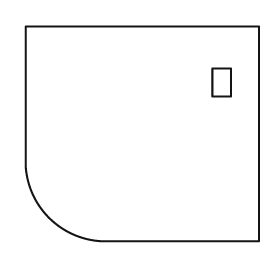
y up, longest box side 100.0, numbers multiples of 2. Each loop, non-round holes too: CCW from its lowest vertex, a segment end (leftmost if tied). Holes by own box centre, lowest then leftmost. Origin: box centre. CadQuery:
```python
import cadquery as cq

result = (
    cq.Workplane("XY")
    .moveTo(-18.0, -46.0)
    .lineTo(50.0, -46.0)
    .lineTo(50.0, 46.0)
    .lineTo(-50.0, 46.0)
    .lineTo(-50.0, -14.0)
    .threePointArc((-40.0, -36.0), (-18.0, -46.0))
    .close()
    .moveTo(30.0, 16.0)
    .lineTo(38.0, 16.0)
    .lineTo(38.0, 28.0)
    .lineTo(30.0, 28.0)
    .close()
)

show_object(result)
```